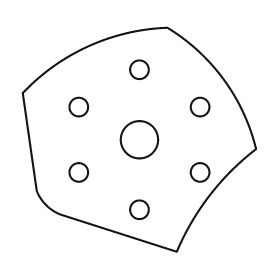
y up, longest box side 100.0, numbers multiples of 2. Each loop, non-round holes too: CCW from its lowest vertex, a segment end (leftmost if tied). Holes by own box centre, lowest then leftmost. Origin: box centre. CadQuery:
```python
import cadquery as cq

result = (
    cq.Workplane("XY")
    .moveTo(16.0, -48.0)
    .threePointArc((30.0, -24.0), (50.0, -4.0))
    .threePointArc((36.0, 26.0), (12.0, 48.0))
    .threePointArc((-22.0, 40.0), (-50.0, 20.0))
    .lineTo(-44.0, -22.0)
    .threePointArc((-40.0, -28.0), (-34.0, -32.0))
    .close()
    .moveTo(0.0, -30.0)
    .circle(4.0)
    .moveTo(-26.0, -14.0)
    .circle(4.0)
    .moveTo(26.0, -14.0)
    .circle(4.0)
    .moveTo(0.0, 0.0)
    .circle(8.0)
    .moveTo(-26.0, 14.0)
    .circle(4.0)
    .moveTo(26.0, 14.0)
    .circle(4.0)
    .moveTo(0.0, 30.0)
    .circle(4.0)
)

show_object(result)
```